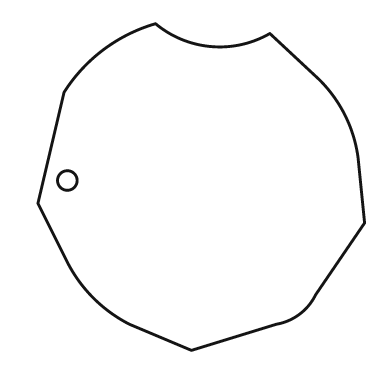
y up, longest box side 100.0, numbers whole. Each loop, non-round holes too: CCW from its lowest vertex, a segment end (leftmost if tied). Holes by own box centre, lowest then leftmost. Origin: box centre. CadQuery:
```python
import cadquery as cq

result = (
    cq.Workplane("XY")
    .moveTo(-3.0, -50.0)
    .lineTo(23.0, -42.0)
    .threePointArc((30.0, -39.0), (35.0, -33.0))
    .lineTo(50.0, -11.0)
    .lineTo(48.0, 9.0)
    .threePointArc((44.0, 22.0), (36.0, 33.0))
    .lineTo(21.0, 47.0)
    .threePointArc((3.0, 43.0), (-14.0, 50.0))
    .threePointArc((-30.0, 42.0), (-42.0, 29.0))
    .lineTo(-50.0, -5.0)
    .lineTo(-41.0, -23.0)
    .threePointArc((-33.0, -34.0), (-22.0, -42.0))
    .close()
    .moveTo(-41.0, 2.0)
    .circle(3.0)
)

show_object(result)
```